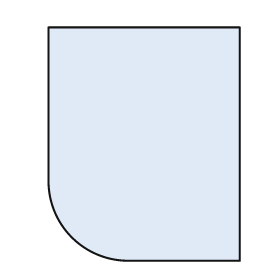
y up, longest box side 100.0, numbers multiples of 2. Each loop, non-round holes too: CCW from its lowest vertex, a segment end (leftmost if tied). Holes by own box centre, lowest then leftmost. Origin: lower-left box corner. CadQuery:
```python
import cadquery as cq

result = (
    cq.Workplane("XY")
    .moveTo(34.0, 0.0)
    .lineTo(82.0, 0.0)
    .lineTo(82.0, 100.0)
    .lineTo(0.0, 100.0)
    .lineTo(0.0, 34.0)
    .threePointArc((10.0, 10.0), (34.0, 0.0))
    .close()
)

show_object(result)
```